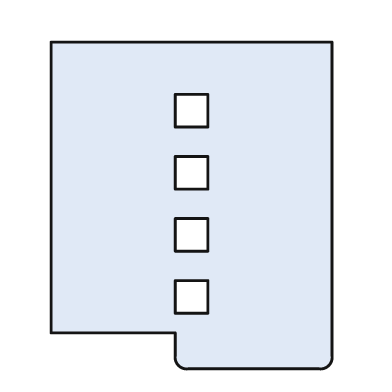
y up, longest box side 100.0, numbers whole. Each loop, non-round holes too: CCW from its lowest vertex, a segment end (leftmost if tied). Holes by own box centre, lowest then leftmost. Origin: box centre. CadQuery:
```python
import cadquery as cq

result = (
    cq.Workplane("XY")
    .moveTo(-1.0, -50.0)
    .lineTo(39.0, -50.0)
    .threePointArc((42.0, -49.0), (43.0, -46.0))
    .lineTo(43.0, 50.0)
    .lineTo(-43.0, 50.0)
    .lineTo(-43.0, -39.0)
    .lineTo(-5.0, -39.0)
    .lineTo(-5.0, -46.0)
    .threePointArc((-4.0, -49.0), (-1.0, -50.0))
    .close()
    .moveTo(-5.0, -33.0)
    .lineTo(5.0, -33.0)
    .lineTo(5.0, -23.0)
    .lineTo(-5.0, -23.0)
    .close()
    .moveTo(-5.0, -14.0)
    .lineTo(5.0, -14.0)
    .lineTo(5.0, -4.0)
    .lineTo(-5.0, -4.0)
    .close()
    .moveTo(-5.0, 5.0)
    .lineTo(5.0, 5.0)
    .lineTo(5.0, 15.0)
    .lineTo(-5.0, 15.0)
    .close()
    .moveTo(-5.0, 24.0)
    .lineTo(5.0, 24.0)
    .lineTo(5.0, 34.0)
    .lineTo(-5.0, 34.0)
    .close()
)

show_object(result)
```